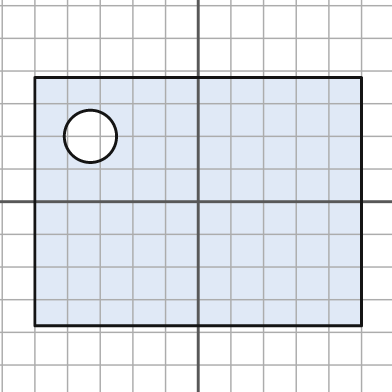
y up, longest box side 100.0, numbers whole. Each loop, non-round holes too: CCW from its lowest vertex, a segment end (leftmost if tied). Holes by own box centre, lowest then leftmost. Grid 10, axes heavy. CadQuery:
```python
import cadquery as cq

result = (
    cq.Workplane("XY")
    .moveTo(-50.0, -38.0)
    .lineTo(50.0, -38.0)
    .lineTo(50.0, 38.0)
    .lineTo(-50.0, 38.0)
    .close()
    .moveTo(-33.0, 20.0)
    .circle(8.0)
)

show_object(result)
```